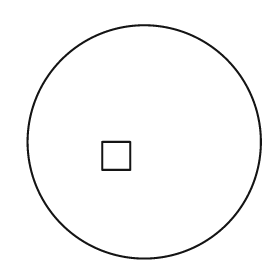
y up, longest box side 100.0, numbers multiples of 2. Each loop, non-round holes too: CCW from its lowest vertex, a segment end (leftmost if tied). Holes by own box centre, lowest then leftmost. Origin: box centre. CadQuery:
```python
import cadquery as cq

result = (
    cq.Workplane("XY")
    .moveTo(0.0, 0.0)
    .circle(50.0)
    .moveTo(-18.0, -12.0)
    .lineTo(-6.0, -12.0)
    .lineTo(-6.0, 0.0)
    .lineTo(-18.0, 0.0)
    .close()
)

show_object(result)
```